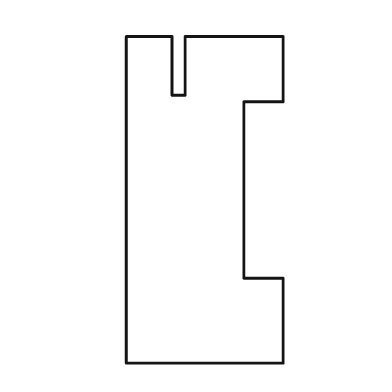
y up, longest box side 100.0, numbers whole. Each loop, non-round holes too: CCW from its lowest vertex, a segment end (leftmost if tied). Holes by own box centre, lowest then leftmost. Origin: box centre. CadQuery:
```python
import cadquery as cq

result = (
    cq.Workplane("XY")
    .moveTo(-24.0, -50.0)
    .lineTo(24.0, -50.0)
    .lineTo(24.0, -24.0)
    .lineTo(12.0, -24.0)
    .lineTo(12.0, 30.0)
    .lineTo(24.0, 30.0)
    .lineTo(24.0, 50.0)
    .lineTo(-6.0, 50.0)
    .lineTo(-6.0, 32.0)
    .lineTo(-10.0, 32.0)
    .lineTo(-10.0, 50.0)
    .lineTo(-24.0, 50.0)
    .close()
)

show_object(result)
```